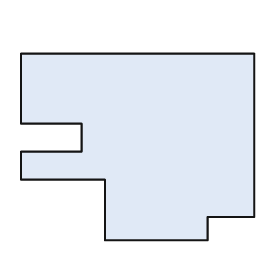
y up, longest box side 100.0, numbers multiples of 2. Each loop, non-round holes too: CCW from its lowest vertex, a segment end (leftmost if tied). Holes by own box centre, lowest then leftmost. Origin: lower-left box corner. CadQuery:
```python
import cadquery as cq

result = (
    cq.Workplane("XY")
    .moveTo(36.0, 0.0)
    .lineTo(80.0, 0.0)
    .lineTo(80.0, 10.0)
    .lineTo(100.0, 10.0)
    .lineTo(100.0, 80.0)
    .lineTo(0.0, 80.0)
    .lineTo(0.0, 50.0)
    .lineTo(26.0, 50.0)
    .lineTo(26.0, 38.0)
    .lineTo(0.0, 38.0)
    .lineTo(0.0, 26.0)
    .lineTo(36.0, 26.0)
    .close()
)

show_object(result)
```